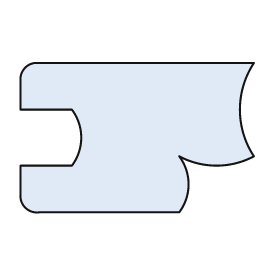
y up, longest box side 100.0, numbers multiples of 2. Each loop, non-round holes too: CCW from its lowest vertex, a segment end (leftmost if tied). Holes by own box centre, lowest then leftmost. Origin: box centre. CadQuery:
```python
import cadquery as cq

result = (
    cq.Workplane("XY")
    .moveTo(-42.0, -32.0)
    .lineTo(18.0, -32.0)
    .threePointArc((22.0, -20.0), (18.0, -8.0))
    .threePointArc((34.0, -12.0), (50.0, -8.0))
    .threePointArc((44.0, 12.0), (50.0, 32.0))
    .lineTo(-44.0, 32.0)
    .threePointArc((-48.0, 30.0), (-50.0, 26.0))
    .lineTo(-50.0, 12.0)
    .lineTo(-28.0, 12.0)
    .threePointArc((-24.0, 0.0), (-28.0, -12.0))
    .lineTo(-50.0, -12.0)
    .lineTo(-50.0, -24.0)
    .threePointArc((-48.0, -30.0), (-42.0, -32.0))
    .close()
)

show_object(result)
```